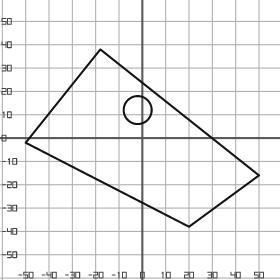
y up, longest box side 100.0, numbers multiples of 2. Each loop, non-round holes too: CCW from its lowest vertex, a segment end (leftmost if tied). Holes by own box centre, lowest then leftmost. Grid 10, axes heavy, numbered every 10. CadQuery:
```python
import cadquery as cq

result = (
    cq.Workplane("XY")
    .moveTo(20.0, -38.0)
    .lineTo(50.0, -16.0)
    .lineTo(-18.0, 38.0)
    .lineTo(-50.0, -2.0)
    .close()
    .moveTo(-2.0, 12.0)
    .circle(6.0)
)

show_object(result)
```